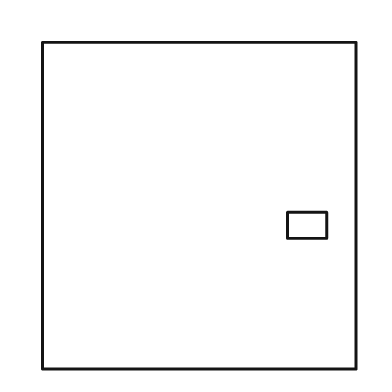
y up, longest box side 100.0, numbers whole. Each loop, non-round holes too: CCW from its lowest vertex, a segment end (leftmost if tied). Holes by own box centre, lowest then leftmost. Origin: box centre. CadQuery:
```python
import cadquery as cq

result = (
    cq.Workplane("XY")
    .moveTo(-48.0, -50.0)
    .lineTo(48.0, -50.0)
    .lineTo(48.0, 50.0)
    .lineTo(-48.0, 50.0)
    .close()
    .moveTo(27.0, -10.0)
    .lineTo(39.0, -10.0)
    .lineTo(39.0, -2.0)
    .lineTo(27.0, -2.0)
    .close()
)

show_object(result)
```